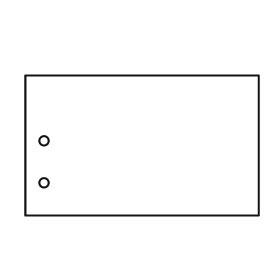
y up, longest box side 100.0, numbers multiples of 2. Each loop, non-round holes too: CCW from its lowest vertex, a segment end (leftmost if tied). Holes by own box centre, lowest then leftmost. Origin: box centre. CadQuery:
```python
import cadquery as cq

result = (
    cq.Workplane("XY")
    .moveTo(-50.0, -30.0)
    .lineTo(50.0, -30.0)
    .lineTo(50.0, 30.0)
    .lineTo(-50.0, 30.0)
    .close()
    .moveTo(-42.0, -16.0)
    .circle(2.0)
    .moveTo(-42.0, 2.0)
    .circle(2.0)
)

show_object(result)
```